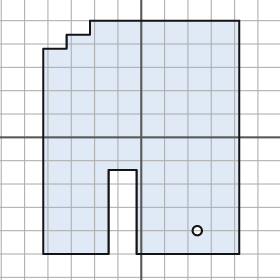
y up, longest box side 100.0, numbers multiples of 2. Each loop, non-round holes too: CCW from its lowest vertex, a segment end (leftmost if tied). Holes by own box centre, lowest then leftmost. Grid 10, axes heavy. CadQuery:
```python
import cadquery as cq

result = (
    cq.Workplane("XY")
    .moveTo(-42.0, -50.0)
    .lineTo(-14.0, -50.0)
    .lineTo(-14.0, -14.0)
    .lineTo(-2.0, -14.0)
    .lineTo(-2.0, -50.0)
    .lineTo(42.0, -50.0)
    .lineTo(42.0, 50.0)
    .lineTo(-22.0, 50.0)
    .lineTo(-22.0, 44.0)
    .lineTo(-32.0, 44.0)
    .lineTo(-32.0, 38.0)
    .lineTo(-42.0, 38.0)
    .close()
    .moveTo(24.0, -40.0)
    .circle(2.0)
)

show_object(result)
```